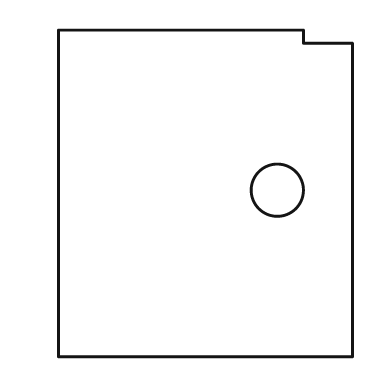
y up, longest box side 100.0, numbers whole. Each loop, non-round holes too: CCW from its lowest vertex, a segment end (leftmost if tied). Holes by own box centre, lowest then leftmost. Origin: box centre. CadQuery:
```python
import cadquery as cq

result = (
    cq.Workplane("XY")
    .moveTo(-45.0, -50.0)
    .lineTo(45.0, -50.0)
    .lineTo(45.0, 46.0)
    .lineTo(30.0, 46.0)
    .lineTo(30.0, 50.0)
    .lineTo(-45.0, 50.0)
    .close()
    .moveTo(22.0, 1.0)
    .circle(8.0)
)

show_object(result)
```